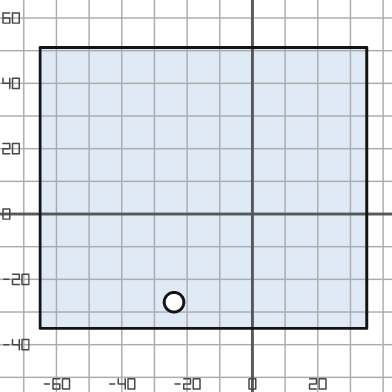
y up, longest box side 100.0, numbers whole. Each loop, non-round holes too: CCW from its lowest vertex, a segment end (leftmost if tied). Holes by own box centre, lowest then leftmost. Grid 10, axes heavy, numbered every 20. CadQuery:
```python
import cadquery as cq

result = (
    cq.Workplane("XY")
    .moveTo(-65.0, -35.0)
    .lineTo(35.0, -35.0)
    .lineTo(35.0, 51.0)
    .lineTo(-65.0, 51.0)
    .close()
    .moveTo(-24.0, -27.0)
    .circle(3.0)
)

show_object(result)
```